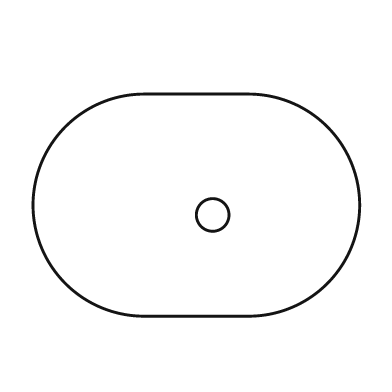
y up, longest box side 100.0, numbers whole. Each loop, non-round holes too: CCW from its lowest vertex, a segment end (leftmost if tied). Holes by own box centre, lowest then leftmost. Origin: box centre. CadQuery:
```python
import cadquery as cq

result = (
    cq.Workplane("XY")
    .moveTo(-16.0, -34.0)
    .lineTo(16.0, -34.0)
    .threePointArc((50.0, 0.0), (16.0, 34.0))
    .lineTo(-16.0, 34.0)
    .threePointArc((-50.0, 0.0), (-16.0, -34.0))
    .close()
    .moveTo(5.0, -3.0)
    .circle(5.0)
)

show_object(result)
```